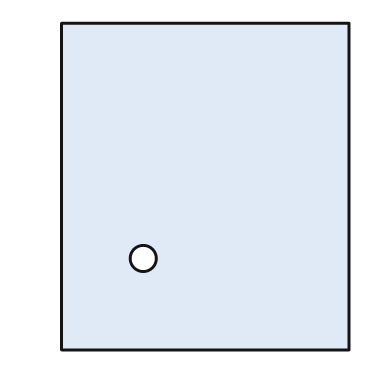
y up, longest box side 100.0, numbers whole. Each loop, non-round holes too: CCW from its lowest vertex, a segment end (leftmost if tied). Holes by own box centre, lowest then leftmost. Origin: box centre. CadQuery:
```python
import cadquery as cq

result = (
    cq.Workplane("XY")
    .moveTo(-44.0, -50.0)
    .lineTo(44.0, -50.0)
    .lineTo(44.0, 50.0)
    .lineTo(-44.0, 50.0)
    .close()
    .moveTo(-19.0, -22.0)
    .circle(4.0)
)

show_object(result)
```